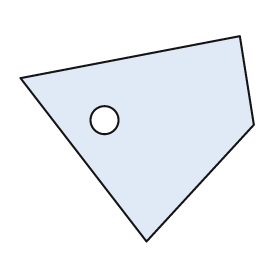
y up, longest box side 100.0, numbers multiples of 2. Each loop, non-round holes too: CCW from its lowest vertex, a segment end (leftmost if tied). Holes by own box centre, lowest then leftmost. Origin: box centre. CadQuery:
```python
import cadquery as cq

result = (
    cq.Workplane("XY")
    .moveTo(4.0, -44.0)
    .lineTo(50.0, 6.0)
    .lineTo(44.0, 44.0)
    .lineTo(-50.0, 26.0)
    .close()
    .moveTo(-14.0, 8.0)
    .circle(6.0)
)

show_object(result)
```